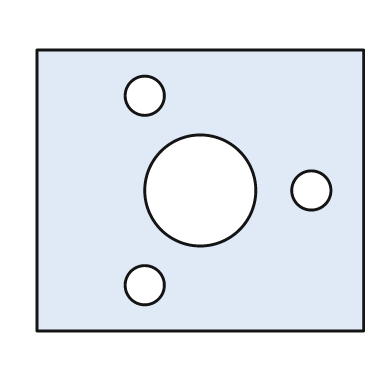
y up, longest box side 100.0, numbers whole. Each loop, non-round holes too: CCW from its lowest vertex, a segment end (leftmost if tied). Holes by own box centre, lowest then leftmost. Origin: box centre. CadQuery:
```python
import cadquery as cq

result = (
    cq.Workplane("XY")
    .moveTo(-50.0, -43.0)
    .lineTo(50.0, -43.0)
    .lineTo(50.0, 43.0)
    .lineTo(-50.0, 43.0)
    .close()
    .moveTo(-17.0, -29.0)
    .circle(6.0)
    .moveTo(0.0, 0.0)
    .circle(17.0)
    .moveTo(34.0, 0.0)
    .circle(6.0)
    .moveTo(-17.0, 29.0)
    .circle(6.0)
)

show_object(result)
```